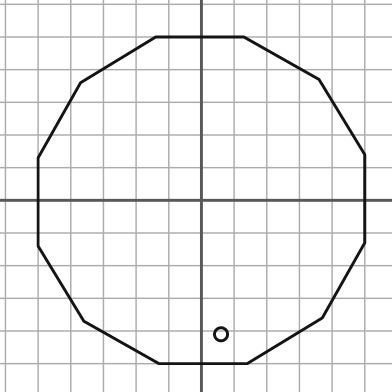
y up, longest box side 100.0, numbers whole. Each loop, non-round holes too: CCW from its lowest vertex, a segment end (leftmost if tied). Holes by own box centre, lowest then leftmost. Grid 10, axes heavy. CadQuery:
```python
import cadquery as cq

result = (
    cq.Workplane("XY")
    .moveTo(-13.0, -50.0)
    .lineTo(14.0, -50.0)
    .lineTo(37.0, -36.0)
    .lineTo(50.0, -13.0)
    .lineTo(50.0, 14.0)
    .lineTo(36.0, 37.0)
    .lineTo(13.0, 50.0)
    .lineTo(-14.0, 50.0)
    .lineTo(-37.0, 36.0)
    .lineTo(-50.0, 13.0)
    .lineTo(-50.0, -14.0)
    .lineTo(-36.0, -37.0)
    .close()
    .moveTo(6.0, -41.0)
    .circle(2.0)
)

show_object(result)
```